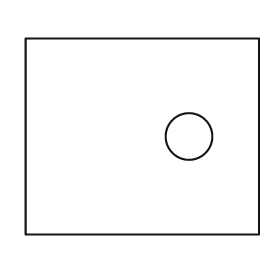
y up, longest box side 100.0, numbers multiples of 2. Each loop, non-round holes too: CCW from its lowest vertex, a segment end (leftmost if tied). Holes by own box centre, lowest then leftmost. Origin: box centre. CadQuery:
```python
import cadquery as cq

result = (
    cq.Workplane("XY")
    .moveTo(-50.0, -42.0)
    .lineTo(50.0, -42.0)
    .lineTo(50.0, 42.0)
    .lineTo(-50.0, 42.0)
    .close()
    .moveTo(20.0, 0.0)
    .circle(10.0)
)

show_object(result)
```